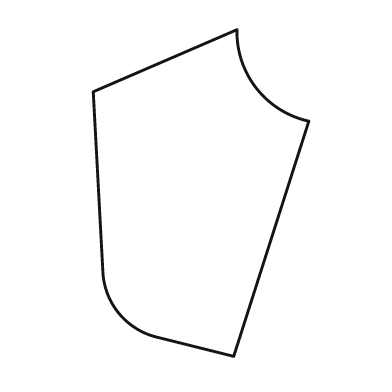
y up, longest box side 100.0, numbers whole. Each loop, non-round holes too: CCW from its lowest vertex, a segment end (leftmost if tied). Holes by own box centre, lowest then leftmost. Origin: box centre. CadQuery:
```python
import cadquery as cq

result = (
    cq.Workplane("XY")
    .moveTo(10.0, -50.0)
    .lineTo(33.0, 22.0)
    .threePointArc((17.0, 32.0), (11.0, 50.0))
    .lineTo(-33.0, 31.0)
    .lineTo(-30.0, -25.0)
    .threePointArc((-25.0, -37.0), (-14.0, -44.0))
    .close()
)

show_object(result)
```